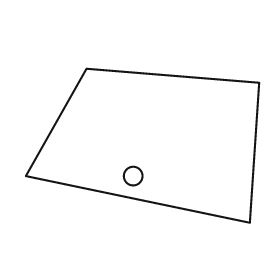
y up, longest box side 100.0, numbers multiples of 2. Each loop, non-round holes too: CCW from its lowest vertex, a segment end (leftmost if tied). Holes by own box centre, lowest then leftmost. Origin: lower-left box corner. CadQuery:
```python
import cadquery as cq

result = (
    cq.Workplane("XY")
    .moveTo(96.0, 0.0)
    .lineTo(100.0, 60.0)
    .lineTo(26.0, 66.0)
    .lineTo(0.0, 20.0)
    .close()
    .moveTo(46.0, 20.0)
    .circle(4.0)
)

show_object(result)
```